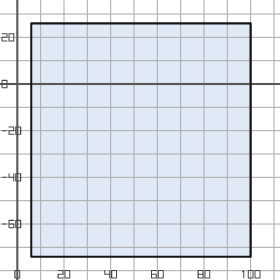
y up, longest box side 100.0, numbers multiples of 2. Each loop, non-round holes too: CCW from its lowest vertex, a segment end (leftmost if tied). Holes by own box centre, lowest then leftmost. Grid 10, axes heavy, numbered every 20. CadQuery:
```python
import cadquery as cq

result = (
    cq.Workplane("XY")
    .moveTo(6.0, -74.0)
    .lineTo(100.0, -74.0)
    .lineTo(100.0, 26.0)
    .lineTo(6.0, 26.0)
    .close()
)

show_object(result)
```